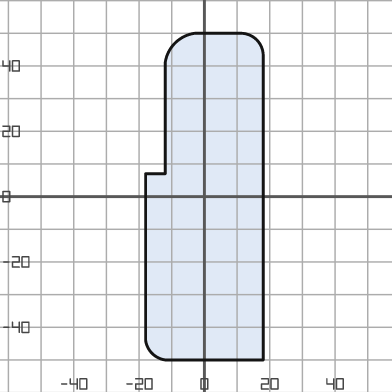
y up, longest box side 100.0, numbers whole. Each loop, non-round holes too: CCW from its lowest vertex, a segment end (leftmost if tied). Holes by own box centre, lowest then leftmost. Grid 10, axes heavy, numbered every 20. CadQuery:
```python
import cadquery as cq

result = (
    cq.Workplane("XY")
    .moveTo(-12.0, -50.0)
    .lineTo(18.0, -50.0)
    .lineTo(18.0, 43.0)
    .threePointArc((16.0, 48.0), (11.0, 50.0))
    .lineTo(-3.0, 50.0)
    .threePointArc((-9.0, 47.0), (-12.0, 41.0))
    .lineTo(-12.0, 7.0)
    .lineTo(-18.0, 7.0)
    .lineTo(-18.0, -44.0)
    .threePointArc((-16.0, -48.0), (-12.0, -50.0))
    .close()
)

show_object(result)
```